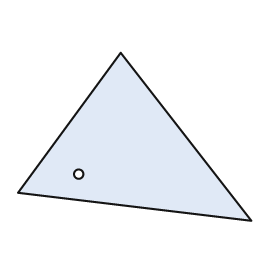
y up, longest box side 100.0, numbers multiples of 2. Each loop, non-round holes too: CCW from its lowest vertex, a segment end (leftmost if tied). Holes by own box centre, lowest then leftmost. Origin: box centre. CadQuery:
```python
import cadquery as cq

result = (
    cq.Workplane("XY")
    .moveTo(50.0, -36.0)
    .lineTo(-6.0, 36.0)
    .lineTo(-50.0, -24.0)
    .close()
    .moveTo(-24.0, -16.0)
    .circle(2.0)
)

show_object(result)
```